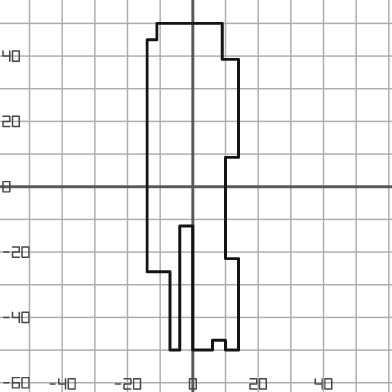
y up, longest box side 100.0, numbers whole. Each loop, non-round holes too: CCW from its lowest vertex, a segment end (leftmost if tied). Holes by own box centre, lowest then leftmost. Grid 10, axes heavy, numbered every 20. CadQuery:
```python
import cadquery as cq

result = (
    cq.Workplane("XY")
    .moveTo(-7.0, -50.0)
    .lineTo(-4.0, -50.0)
    .lineTo(-4.0, -12.0)
    .lineTo(0.0, -12.0)
    .lineTo(0.0, -50.0)
    .lineTo(6.0, -50.0)
    .lineTo(6.0, -47.0)
    .lineTo(10.0, -47.0)
    .lineTo(10.0, -50.0)
    .lineTo(14.0, -50.0)
    .lineTo(14.0, -22.0)
    .lineTo(10.0, -22.0)
    .lineTo(10.0, 9.0)
    .lineTo(14.0, 9.0)
    .lineTo(14.0, 39.0)
    .lineTo(9.0, 39.0)
    .lineTo(9.0, 50.0)
    .lineTo(-11.0, 50.0)
    .lineTo(-11.0, 45.0)
    .lineTo(-14.0, 45.0)
    .lineTo(-14.0, -26.0)
    .lineTo(-7.0, -26.0)
    .close()
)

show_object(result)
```